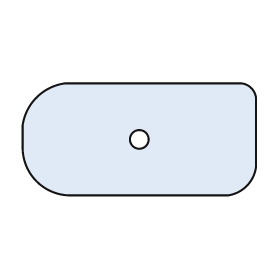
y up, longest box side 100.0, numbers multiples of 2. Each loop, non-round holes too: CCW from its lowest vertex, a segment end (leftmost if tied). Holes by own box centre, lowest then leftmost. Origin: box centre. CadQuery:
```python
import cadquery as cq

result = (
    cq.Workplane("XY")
    .moveTo(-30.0, -24.0)
    .lineTo(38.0, -24.0)
    .threePointArc((46.0, -20.0), (50.0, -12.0))
    .lineTo(50.0, 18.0)
    .threePointArc((48.0, 22.0), (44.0, 24.0))
    .lineTo(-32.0, 24.0)
    .threePointArc((-44.0, 18.0), (-50.0, 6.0))
    .lineTo(-50.0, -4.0)
    .threePointArc((-44.0, -18.0), (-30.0, -24.0))
    .close()
    .moveTo(0.0, 0.0)
    .circle(4.0)
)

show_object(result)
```